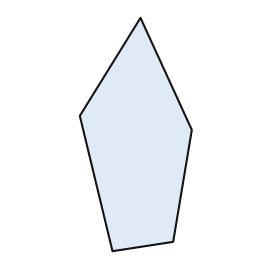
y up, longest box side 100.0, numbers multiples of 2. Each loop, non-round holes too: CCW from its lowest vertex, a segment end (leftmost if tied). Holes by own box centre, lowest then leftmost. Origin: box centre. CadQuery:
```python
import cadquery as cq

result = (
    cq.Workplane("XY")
    .moveTo(-10.0, -50.0)
    .lineTo(16.0, -46.0)
    .lineTo(24.0, 2.0)
    .lineTo(2.0, 50.0)
    .lineTo(-24.0, 8.0)
    .close()
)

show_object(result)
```